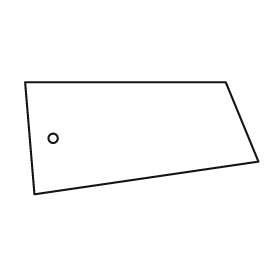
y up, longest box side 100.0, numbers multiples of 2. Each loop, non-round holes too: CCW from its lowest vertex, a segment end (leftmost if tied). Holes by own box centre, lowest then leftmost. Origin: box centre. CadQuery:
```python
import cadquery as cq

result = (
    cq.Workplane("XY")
    .moveTo(-46.0, -24.0)
    .lineTo(50.0, -10.0)
    .lineTo(36.0, 24.0)
    .lineTo(-50.0, 24.0)
    .close()
    .moveTo(-38.0, 0.0)
    .circle(2.0)
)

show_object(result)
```